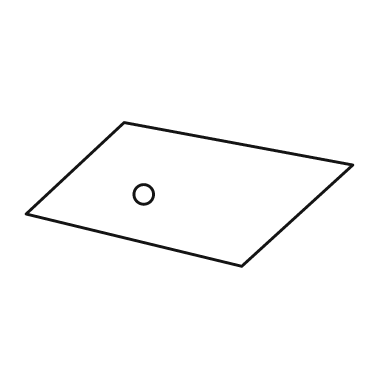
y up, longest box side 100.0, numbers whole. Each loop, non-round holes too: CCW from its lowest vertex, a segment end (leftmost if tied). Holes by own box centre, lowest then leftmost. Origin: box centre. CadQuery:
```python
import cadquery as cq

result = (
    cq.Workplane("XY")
    .moveTo(16.0, -22.0)
    .lineTo(50.0, 9.0)
    .lineTo(-20.0, 22.0)
    .lineTo(-50.0, -6.0)
    .close()
    .moveTo(-14.0, 0.0)
    .circle(3.0)
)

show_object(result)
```